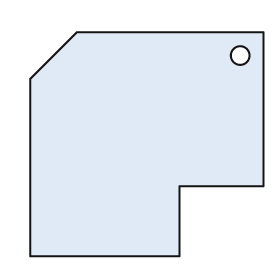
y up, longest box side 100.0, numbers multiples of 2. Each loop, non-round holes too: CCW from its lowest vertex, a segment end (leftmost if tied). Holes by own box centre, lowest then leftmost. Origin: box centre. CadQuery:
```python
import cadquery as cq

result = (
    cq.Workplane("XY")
    .moveTo(-50.0, -48.0)
    .lineTo(14.0, -48.0)
    .lineTo(14.0, -18.0)
    .lineTo(50.0, -18.0)
    .lineTo(50.0, 48.0)
    .lineTo(-30.0, 48.0)
    .lineTo(-50.0, 28.0)
    .close()
    .moveTo(40.0, 38.0)
    .circle(4.0)
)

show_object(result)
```